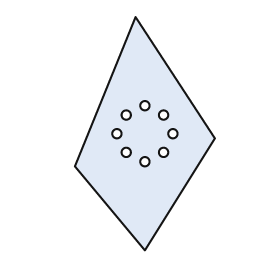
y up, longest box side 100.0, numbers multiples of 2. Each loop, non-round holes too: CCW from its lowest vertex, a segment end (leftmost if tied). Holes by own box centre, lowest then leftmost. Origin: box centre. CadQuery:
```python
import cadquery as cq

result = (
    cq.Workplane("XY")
    .moveTo(0.0, -50.0)
    .lineTo(30.0, -2.0)
    .lineTo(-4.0, 50.0)
    .lineTo(-30.0, -14.0)
    .close()
    .moveTo(0.0, -12.0)
    .circle(2.0)
    .moveTo(-8.0, -8.0)
    .circle(2.0)
    .moveTo(8.0, -8.0)
    .circle(2.0)
    .moveTo(-12.0, 0.0)
    .circle(2.0)
    .moveTo(12.0, 0.0)
    .circle(2.0)
    .moveTo(-8.0, 8.0)
    .circle(2.0)
    .moveTo(8.0, 8.0)
    .circle(2.0)
    .moveTo(0.0, 12.0)
    .circle(2.0)
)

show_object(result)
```